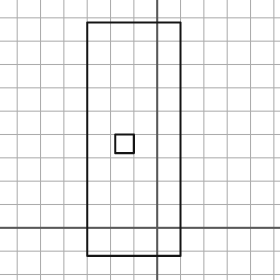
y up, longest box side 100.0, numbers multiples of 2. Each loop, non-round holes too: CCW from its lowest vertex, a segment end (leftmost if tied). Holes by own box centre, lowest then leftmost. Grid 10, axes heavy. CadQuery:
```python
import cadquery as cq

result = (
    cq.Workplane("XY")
    .moveTo(-30.0, -12.0)
    .lineTo(10.0, -12.0)
    .lineTo(10.0, 88.0)
    .lineTo(-30.0, 88.0)
    .close()
    .moveTo(-18.0, 32.0)
    .lineTo(-10.0, 32.0)
    .lineTo(-10.0, 40.0)
    .lineTo(-18.0, 40.0)
    .close()
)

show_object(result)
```